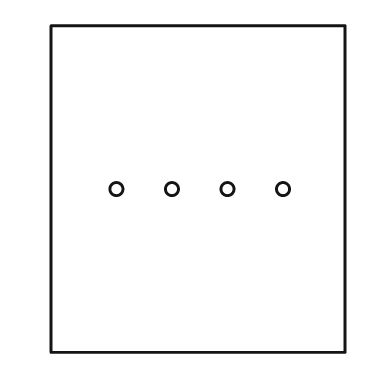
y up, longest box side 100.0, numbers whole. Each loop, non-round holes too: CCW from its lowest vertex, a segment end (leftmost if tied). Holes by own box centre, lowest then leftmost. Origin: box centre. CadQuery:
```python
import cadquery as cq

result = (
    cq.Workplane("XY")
    .moveTo(-45.0, -50.0)
    .lineTo(45.0, -50.0)
    .lineTo(45.0, 50.0)
    .lineTo(-45.0, 50.0)
    .close()
    .moveTo(-25.0, 0.0)
    .circle(2.0)
    .moveTo(-8.0, 0.0)
    .circle(2.0)
    .moveTo(9.0, 0.0)
    .circle(2.0)
    .moveTo(26.0, 0.0)
    .circle(2.0)
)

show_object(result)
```